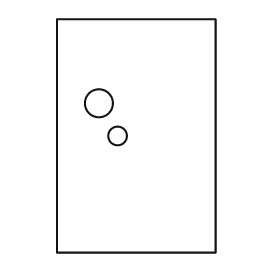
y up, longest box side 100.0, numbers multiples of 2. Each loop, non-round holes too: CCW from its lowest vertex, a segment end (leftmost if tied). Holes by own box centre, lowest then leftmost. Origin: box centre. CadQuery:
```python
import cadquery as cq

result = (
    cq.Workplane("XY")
    .moveTo(-34.0, -50.0)
    .lineTo(34.0, -50.0)
    .lineTo(34.0, 50.0)
    .lineTo(-34.0, 50.0)
    .close()
    .moveTo(-8.0, 0.0)
    .circle(4.0)
    .moveTo(-16.0, 14.0)
    .circle(6.0)
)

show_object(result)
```